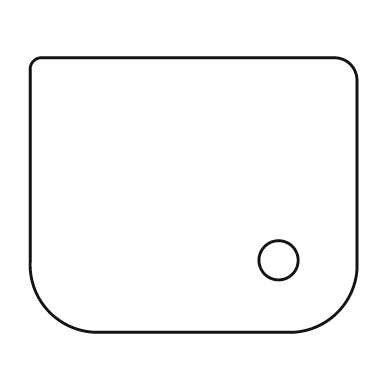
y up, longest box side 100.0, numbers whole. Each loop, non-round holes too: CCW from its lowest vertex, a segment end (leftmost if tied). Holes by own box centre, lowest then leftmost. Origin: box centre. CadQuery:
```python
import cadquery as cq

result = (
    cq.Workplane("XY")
    .moveTo(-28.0, -42.0)
    .lineTo(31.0, -42.0)
    .threePointArc((44.0, -36.0), (50.0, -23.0))
    .lineTo(50.0, 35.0)
    .threePointArc((48.0, 40.0), (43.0, 42.0))
    .lineTo(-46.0, 42.0)
    .threePointArc((-49.0, 41.0), (-50.0, 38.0))
    .lineTo(-50.0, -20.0)
    .threePointArc((-44.0, -36.0), (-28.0, -42.0))
    .close()
    .moveTo(26.0, -20.0)
    .circle(6.0)
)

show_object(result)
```